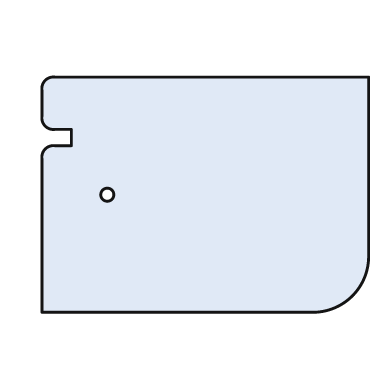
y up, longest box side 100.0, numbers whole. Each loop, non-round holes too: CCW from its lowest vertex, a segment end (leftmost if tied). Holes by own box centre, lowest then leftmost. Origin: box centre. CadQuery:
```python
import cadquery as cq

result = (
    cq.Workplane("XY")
    .moveTo(-50.0, -36.0)
    .lineTo(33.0, -36.0)
    .threePointArc((45.0, -31.0), (50.0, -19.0))
    .lineTo(50.0, 36.0)
    .lineTo(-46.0, 36.0)
    .threePointArc((-49.0, 35.0), (-50.0, 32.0))
    .lineTo(-50.0, 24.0)
    .threePointArc((-49.0, 21.0), (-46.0, 20.0))
    .lineTo(-41.0, 20.0)
    .lineTo(-41.0, 15.0)
    .lineTo(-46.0, 15.0)
    .threePointArc((-49.0, 14.0), (-50.0, 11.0))
    .close()
    .moveTo(-30.0, 0.0)
    .circle(2.0)
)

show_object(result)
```